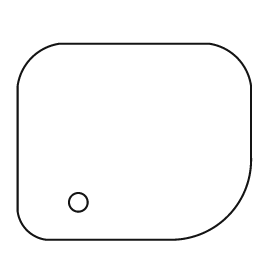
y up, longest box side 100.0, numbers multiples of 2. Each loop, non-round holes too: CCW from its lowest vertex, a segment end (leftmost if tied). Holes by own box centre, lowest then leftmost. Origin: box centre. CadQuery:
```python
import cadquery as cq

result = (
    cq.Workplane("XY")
    .moveTo(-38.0, -42.0)
    .lineTo(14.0, -42.0)
    .threePointArc((40.0, -32.0), (50.0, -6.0))
    .lineTo(50.0, 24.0)
    .threePointArc((44.0, 36.0), (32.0, 42.0))
    .lineTo(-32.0, 42.0)
    .threePointArc((-44.0, 36.0), (-50.0, 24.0))
    .lineTo(-50.0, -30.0)
    .threePointArc((-46.0, -38.0), (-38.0, -42.0))
    .close()
    .moveTo(-24.0, -26.0)
    .circle(4.0)
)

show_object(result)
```